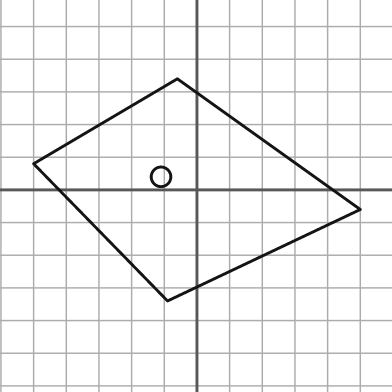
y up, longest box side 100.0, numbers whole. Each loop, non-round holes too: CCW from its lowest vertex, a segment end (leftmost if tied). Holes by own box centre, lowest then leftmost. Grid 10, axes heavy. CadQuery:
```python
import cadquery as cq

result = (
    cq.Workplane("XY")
    .moveTo(-9.0, -34.0)
    .lineTo(50.0, -6.0)
    .lineTo(-6.0, 34.0)
    .lineTo(-50.0, 8.0)
    .close()
    .moveTo(-11.0, 4.0)
    .circle(3.0)
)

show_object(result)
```